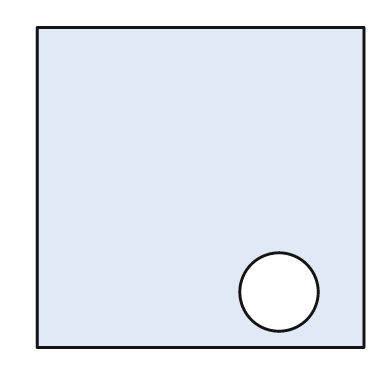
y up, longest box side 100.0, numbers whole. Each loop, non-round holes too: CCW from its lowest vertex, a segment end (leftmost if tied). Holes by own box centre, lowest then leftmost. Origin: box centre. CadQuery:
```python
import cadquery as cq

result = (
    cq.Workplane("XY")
    .moveTo(-50.0, -49.0)
    .lineTo(50.0, -49.0)
    .lineTo(50.0, 49.0)
    .lineTo(-50.0, 49.0)
    .close()
    .moveTo(24.0, -32.0)
    .circle(12.0)
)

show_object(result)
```